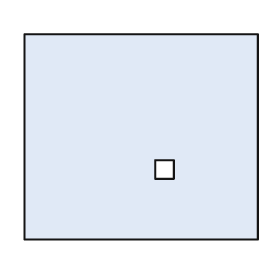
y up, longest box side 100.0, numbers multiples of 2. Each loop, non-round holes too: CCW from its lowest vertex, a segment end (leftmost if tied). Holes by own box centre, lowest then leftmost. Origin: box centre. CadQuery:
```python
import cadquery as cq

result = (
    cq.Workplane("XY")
    .moveTo(-50.0, -44.0)
    .lineTo(50.0, -44.0)
    .lineTo(50.0, 44.0)
    .lineTo(-50.0, 44.0)
    .close()
    .moveTo(6.0, -18.0)
    .lineTo(14.0, -18.0)
    .lineTo(14.0, -10.0)
    .lineTo(6.0, -10.0)
    .close()
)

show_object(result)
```